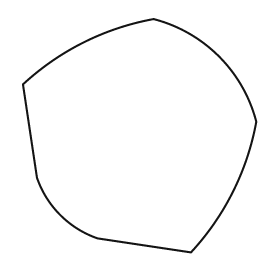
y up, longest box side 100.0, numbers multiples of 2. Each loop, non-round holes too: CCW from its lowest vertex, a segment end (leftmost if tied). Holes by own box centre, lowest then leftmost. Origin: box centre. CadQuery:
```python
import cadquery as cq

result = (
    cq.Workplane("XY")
    .moveTo(22.0, -50.0)
    .threePointArc((40.0, -24.0), (50.0, 6.0))
    .threePointArc((34.0, 34.0), (6.0, 50.0))
    .threePointArc((-24.0, 40.0), (-50.0, 22.0))
    .lineTo(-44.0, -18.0)
    .threePointArc((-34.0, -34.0), (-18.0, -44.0))
    .close()
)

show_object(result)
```